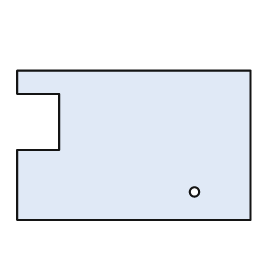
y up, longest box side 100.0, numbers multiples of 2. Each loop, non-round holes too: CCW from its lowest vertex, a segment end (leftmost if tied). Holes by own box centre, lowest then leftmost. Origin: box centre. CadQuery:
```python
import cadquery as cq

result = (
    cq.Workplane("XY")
    .moveTo(-50.0, -32.0)
    .lineTo(50.0, -32.0)
    .lineTo(50.0, 32.0)
    .lineTo(-50.0, 32.0)
    .lineTo(-50.0, 22.0)
    .lineTo(-32.0, 22.0)
    .lineTo(-32.0, -2.0)
    .lineTo(-50.0, -2.0)
    .close()
    .moveTo(26.0, -20.0)
    .circle(2.0)
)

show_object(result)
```